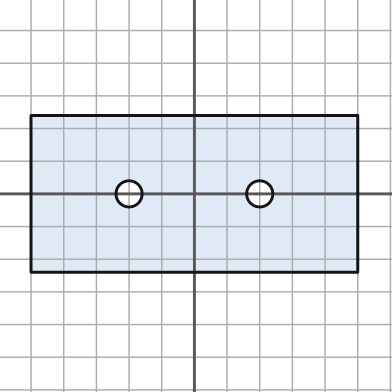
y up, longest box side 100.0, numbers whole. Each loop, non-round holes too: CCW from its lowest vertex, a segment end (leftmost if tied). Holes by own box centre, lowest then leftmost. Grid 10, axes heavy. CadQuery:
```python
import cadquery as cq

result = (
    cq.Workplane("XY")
    .moveTo(-50.0, -24.0)
    .lineTo(50.0, -24.0)
    .lineTo(50.0, 24.0)
    .lineTo(-50.0, 24.0)
    .close()
    .moveTo(-20.0, 0.0)
    .circle(4.0)
    .moveTo(20.0, 0.0)
    .circle(4.0)
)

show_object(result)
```